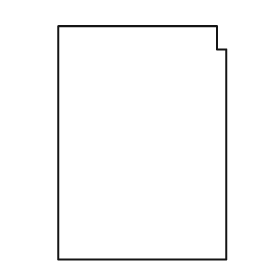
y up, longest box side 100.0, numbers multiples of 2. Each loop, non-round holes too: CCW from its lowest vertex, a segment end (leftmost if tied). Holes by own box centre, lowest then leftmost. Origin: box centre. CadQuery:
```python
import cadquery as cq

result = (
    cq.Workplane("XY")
    .moveTo(-36.0, -50.0)
    .lineTo(36.0, -50.0)
    .lineTo(36.0, 40.0)
    .lineTo(32.0, 40.0)
    .lineTo(32.0, 50.0)
    .lineTo(-36.0, 50.0)
    .close()
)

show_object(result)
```